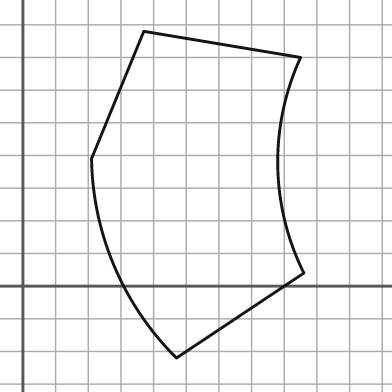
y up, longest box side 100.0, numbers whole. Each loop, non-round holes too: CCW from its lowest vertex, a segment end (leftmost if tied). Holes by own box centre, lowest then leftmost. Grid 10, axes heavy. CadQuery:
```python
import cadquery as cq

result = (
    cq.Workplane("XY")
    .moveTo(47.0, -22.0)
    .lineTo(86.0, 4.0)
    .threePointArc((78.0, 37.0), (85.0, 70.0))
    .lineTo(37.0, 78.0)
    .lineTo(21.0, 39.0)
    .threePointArc((28.0, 6.0), (47.0, -22.0))
    .close()
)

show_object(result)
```